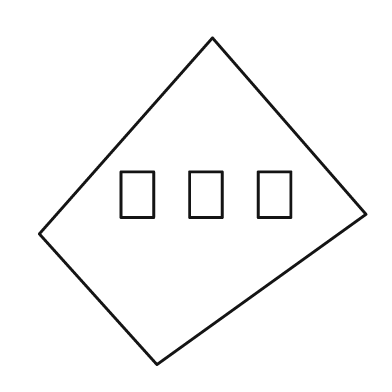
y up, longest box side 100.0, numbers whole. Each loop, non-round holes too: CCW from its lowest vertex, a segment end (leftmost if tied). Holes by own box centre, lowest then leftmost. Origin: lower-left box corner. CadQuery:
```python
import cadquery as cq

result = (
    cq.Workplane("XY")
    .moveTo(36.0, 0.0)
    .lineTo(100.0, 46.0)
    .lineTo(53.0, 100.0)
    .lineTo(0.0, 40.0)
    .close()
    .moveTo(25.0, 45.0)
    .lineTo(35.0, 45.0)
    .lineTo(35.0, 59.0)
    .lineTo(25.0, 59.0)
    .close()
    .moveTo(46.0, 45.0)
    .lineTo(56.0, 45.0)
    .lineTo(56.0, 59.0)
    .lineTo(46.0, 59.0)
    .close()
    .moveTo(67.0, 45.0)
    .lineTo(77.0, 45.0)
    .lineTo(77.0, 59.0)
    .lineTo(67.0, 59.0)
    .close()
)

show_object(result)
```